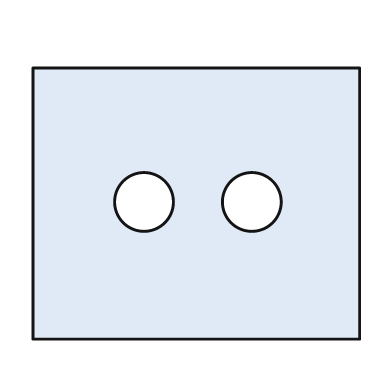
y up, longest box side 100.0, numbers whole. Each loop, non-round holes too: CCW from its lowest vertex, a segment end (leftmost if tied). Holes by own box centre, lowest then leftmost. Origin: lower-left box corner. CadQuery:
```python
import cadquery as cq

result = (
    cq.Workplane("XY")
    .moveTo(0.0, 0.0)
    .lineTo(100.0, 0.0)
    .lineTo(100.0, 83.0)
    .lineTo(0.0, 83.0)
    .close()
    .moveTo(34.0, 42.0)
    .circle(9.0)
    .moveTo(67.0, 42.0)
    .circle(9.0)
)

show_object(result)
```